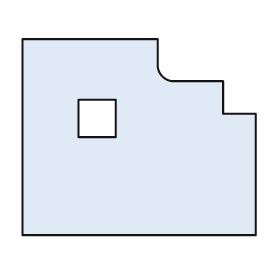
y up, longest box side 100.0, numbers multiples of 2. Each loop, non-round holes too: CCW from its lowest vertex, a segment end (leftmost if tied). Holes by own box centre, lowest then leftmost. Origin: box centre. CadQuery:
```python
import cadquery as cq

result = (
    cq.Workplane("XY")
    .moveTo(-50.0, -42.0)
    .lineTo(50.0, -42.0)
    .lineTo(50.0, 10.0)
    .lineTo(36.0, 10.0)
    .lineTo(36.0, 24.0)
    .lineTo(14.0, 24.0)
    .threePointArc((10.0, 26.0), (8.0, 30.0))
    .lineTo(8.0, 42.0)
    .lineTo(-50.0, 42.0)
    .close()
    .moveTo(-26.0, 0.0)
    .lineTo(-10.0, 0.0)
    .lineTo(-10.0, 16.0)
    .lineTo(-26.0, 16.0)
    .close()
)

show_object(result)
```